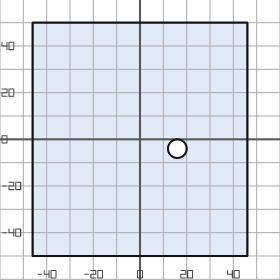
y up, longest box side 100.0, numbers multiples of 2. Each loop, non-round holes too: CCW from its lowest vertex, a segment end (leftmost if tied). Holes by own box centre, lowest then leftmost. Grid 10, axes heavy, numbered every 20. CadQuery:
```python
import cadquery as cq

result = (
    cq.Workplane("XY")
    .moveTo(-46.0, -50.0)
    .lineTo(46.0, -50.0)
    .lineTo(46.0, 50.0)
    .lineTo(-46.0, 50.0)
    .close()
    .moveTo(16.0, -4.0)
    .circle(4.0)
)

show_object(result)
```